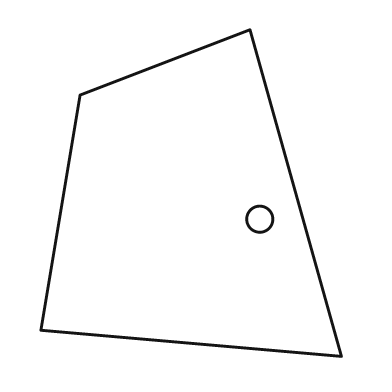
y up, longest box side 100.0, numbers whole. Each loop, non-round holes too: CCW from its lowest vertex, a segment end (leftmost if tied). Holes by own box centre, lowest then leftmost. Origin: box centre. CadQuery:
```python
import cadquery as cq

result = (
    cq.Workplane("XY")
    .moveTo(46.0, -50.0)
    .lineTo(18.0, 50.0)
    .lineTo(-34.0, 30.0)
    .lineTo(-46.0, -42.0)
    .close()
    .moveTo(21.0, -8.0)
    .circle(4.0)
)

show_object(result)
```